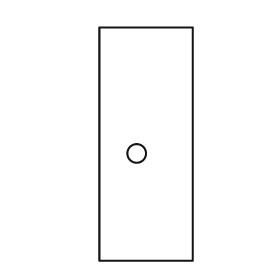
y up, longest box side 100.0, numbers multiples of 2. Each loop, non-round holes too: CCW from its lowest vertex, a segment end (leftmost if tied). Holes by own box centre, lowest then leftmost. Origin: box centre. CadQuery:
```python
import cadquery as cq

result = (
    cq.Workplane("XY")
    .moveTo(-20.0, -50.0)
    .lineTo(20.0, -50.0)
    .lineTo(20.0, 50.0)
    .lineTo(-20.0, 50.0)
    .close()
    .moveTo(-4.0, -4.0)
    .circle(4.0)
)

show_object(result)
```